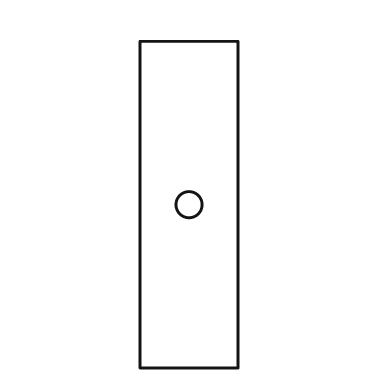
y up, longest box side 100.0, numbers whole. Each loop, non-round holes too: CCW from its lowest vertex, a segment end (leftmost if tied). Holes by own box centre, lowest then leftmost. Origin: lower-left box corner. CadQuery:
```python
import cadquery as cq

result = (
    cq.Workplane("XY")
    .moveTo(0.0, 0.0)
    .lineTo(30.0, 0.0)
    .lineTo(30.0, 100.0)
    .lineTo(0.0, 100.0)
    .close()
    .moveTo(15.0, 50.0)
    .circle(4.0)
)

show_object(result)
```